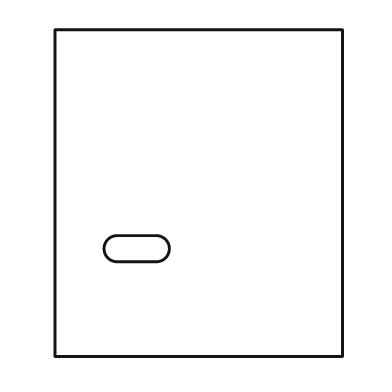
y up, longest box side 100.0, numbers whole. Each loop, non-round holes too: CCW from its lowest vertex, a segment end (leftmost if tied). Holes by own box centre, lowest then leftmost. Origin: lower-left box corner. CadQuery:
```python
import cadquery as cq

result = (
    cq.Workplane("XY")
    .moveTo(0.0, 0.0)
    .lineTo(88.0, 0.0)
    .lineTo(88.0, 100.0)
    .lineTo(0.0, 100.0)
    .close()
    .moveTo(19.0, 29.0)
    .lineTo(31.0, 29.0)
    .threePointArc((35.0, 33.0), (31.0, 37.0))
    .lineTo(19.0, 37.0)
    .threePointArc((15.0, 33.0), (19.0, 29.0))
    .close()
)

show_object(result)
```